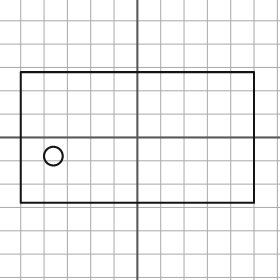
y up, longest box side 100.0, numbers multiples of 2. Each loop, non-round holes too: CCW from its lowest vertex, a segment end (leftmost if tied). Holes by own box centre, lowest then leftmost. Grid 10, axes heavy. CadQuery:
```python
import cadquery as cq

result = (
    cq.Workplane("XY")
    .moveTo(-50.0, -28.0)
    .lineTo(50.0, -28.0)
    .lineTo(50.0, 28.0)
    .lineTo(-50.0, 28.0)
    .close()
    .moveTo(-36.0, -8.0)
    .circle(4.0)
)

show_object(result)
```